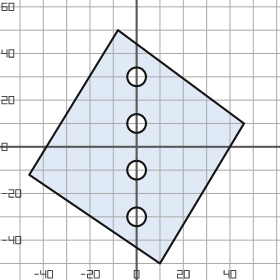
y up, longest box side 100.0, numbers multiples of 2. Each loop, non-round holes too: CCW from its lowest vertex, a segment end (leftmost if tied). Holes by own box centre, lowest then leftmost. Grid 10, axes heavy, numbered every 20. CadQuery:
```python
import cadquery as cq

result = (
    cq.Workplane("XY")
    .moveTo(10.0, -50.0)
    .lineTo(46.0, 10.0)
    .lineTo(-8.0, 50.0)
    .lineTo(-46.0, -12.0)
    .close()
    .moveTo(0.0, -30.0)
    .circle(4.0)
    .moveTo(0.0, -10.0)
    .circle(4.0)
    .moveTo(0.0, 10.0)
    .circle(4.0)
    .moveTo(0.0, 30.0)
    .circle(4.0)
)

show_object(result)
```